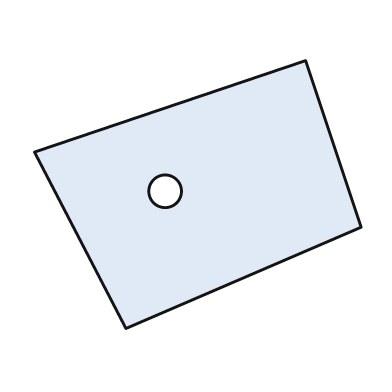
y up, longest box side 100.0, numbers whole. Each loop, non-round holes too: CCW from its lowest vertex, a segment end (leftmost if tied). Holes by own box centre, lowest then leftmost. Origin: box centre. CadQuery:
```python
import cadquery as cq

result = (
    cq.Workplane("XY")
    .moveTo(-22.0, -41.0)
    .lineTo(50.0, -10.0)
    .lineTo(33.0, 41.0)
    .lineTo(-50.0, 13.0)
    .close()
    .moveTo(-10.0, 1.0)
    .circle(5.0)
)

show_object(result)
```